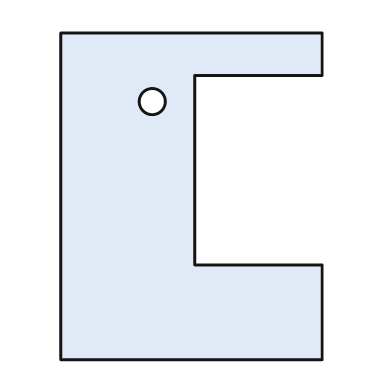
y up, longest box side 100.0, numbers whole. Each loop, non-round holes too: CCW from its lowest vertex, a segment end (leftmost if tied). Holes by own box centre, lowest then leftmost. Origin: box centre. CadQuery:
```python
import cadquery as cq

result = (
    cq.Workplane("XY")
    .moveTo(-40.0, -50.0)
    .lineTo(40.0, -50.0)
    .lineTo(40.0, -21.0)
    .lineTo(1.0, -21.0)
    .lineTo(1.0, 37.0)
    .lineTo(40.0, 37.0)
    .lineTo(40.0, 50.0)
    .lineTo(-40.0, 50.0)
    .close()
    .moveTo(-12.0, 29.0)
    .circle(4.0)
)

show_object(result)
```